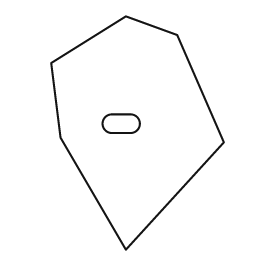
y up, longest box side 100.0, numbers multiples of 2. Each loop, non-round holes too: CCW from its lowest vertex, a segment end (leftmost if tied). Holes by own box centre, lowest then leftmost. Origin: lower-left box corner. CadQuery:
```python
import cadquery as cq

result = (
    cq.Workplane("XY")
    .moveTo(32.0, 0.0)
    .lineTo(74.0, 46.0)
    .lineTo(54.0, 92.0)
    .lineTo(32.0, 100.0)
    .lineTo(0.0, 80.0)
    .lineTo(4.0, 48.0)
    .close()
    .moveTo(26.0, 50.0)
    .lineTo(34.0, 50.0)
    .threePointArc((38.0, 54.0), (34.0, 58.0))
    .lineTo(26.0, 58.0)
    .threePointArc((22.0, 54.0), (26.0, 50.0))
    .close()
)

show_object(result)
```